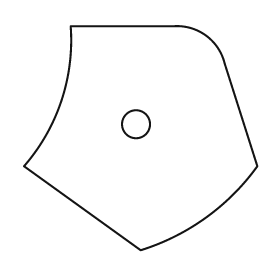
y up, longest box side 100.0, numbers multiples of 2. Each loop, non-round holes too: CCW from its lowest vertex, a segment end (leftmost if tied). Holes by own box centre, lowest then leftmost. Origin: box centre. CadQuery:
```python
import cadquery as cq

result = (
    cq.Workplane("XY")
    .moveTo(0.0, -48.0)
    .threePointArc((28.0, -34.0), (50.0, -12.0))
    .lineTo(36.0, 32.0)
    .threePointArc((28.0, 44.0), (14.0, 48.0))
    .lineTo(-30.0, 48.0)
    .threePointArc((-34.0, 16.0), (-50.0, -12.0))
    .close()
    .moveTo(-2.0, 6.0)
    .circle(6.0)
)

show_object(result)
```